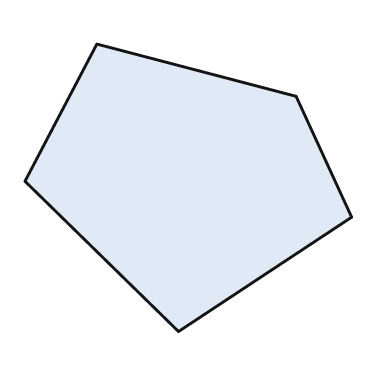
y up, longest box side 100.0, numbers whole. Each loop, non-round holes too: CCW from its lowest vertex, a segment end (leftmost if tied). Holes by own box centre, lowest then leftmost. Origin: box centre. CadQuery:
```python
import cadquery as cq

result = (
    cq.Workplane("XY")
    .moveTo(-3.0, -44.0)
    .lineTo(50.0, -9.0)
    .lineTo(33.0, 28.0)
    .lineTo(-28.0, 44.0)
    .lineTo(-50.0, 2.0)
    .close()
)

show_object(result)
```